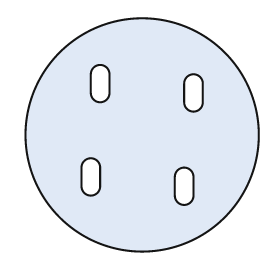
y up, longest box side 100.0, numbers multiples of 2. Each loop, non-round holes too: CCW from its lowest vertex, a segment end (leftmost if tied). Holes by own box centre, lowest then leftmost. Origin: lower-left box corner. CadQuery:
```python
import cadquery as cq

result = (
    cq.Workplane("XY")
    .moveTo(50.0, 50.0)
    .circle(50.0)
    .moveTo(64.0, 24.0)
    .threePointArc((68.0, 20.0), (72.0, 24.0))
    .lineTo(72.0, 32.0)
    .threePointArc((68.0, 36.0), (64.0, 32.0))
    .close()
    .moveTo(24.0, 28.0)
    .threePointArc((28.0, 24.0), (32.0, 28.0))
    .lineTo(32.0, 36.0)
    .threePointArc((28.0, 40.0), (24.0, 36.0))
    .close()
    .moveTo(68.0, 64.0)
    .threePointArc((72.0, 60.0), (76.0, 64.0))
    .lineTo(76.0, 72.0)
    .threePointArc((72.0, 76.0), (68.0, 72.0))
    .close()
    .moveTo(28.0, 68.0)
    .threePointArc((32.0, 64.0), (36.0, 68.0))
    .lineTo(36.0, 76.0)
    .threePointArc((32.0, 80.0), (28.0, 76.0))
    .close()
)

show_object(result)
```